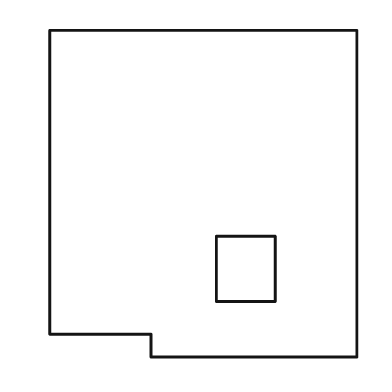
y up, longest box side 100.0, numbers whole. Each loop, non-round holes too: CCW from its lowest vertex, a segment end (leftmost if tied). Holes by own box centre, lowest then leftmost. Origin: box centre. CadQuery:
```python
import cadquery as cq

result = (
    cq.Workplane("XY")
    .moveTo(-16.0, -50.0)
    .lineTo(47.0, -50.0)
    .lineTo(47.0, 50.0)
    .lineTo(-47.0, 50.0)
    .lineTo(-47.0, -43.0)
    .lineTo(-16.0, -43.0)
    .close()
    .moveTo(4.0, -33.0)
    .lineTo(22.0, -33.0)
    .lineTo(22.0, -13.0)
    .lineTo(4.0, -13.0)
    .close()
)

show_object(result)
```